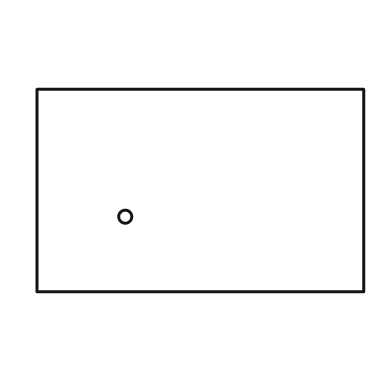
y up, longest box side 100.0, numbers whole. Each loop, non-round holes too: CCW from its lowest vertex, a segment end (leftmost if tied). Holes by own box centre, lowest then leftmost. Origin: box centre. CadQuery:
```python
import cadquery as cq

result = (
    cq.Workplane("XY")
    .moveTo(-50.0, -31.0)
    .lineTo(50.0, -31.0)
    .lineTo(50.0, 31.0)
    .lineTo(-50.0, 31.0)
    .close()
    .moveTo(-23.0, -8.0)
    .circle(2.0)
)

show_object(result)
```